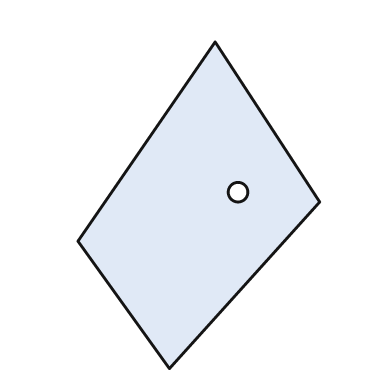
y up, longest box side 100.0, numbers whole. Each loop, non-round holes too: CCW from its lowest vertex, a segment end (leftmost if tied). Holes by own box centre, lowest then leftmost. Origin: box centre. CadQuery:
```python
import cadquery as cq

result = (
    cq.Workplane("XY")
    .moveTo(-9.0, -50.0)
    .lineTo(37.0, 1.0)
    .lineTo(5.0, 50.0)
    .lineTo(-37.0, -11.0)
    .close()
    .moveTo(12.0, 4.0)
    .circle(3.0)
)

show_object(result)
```